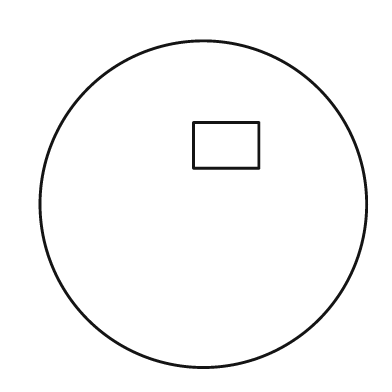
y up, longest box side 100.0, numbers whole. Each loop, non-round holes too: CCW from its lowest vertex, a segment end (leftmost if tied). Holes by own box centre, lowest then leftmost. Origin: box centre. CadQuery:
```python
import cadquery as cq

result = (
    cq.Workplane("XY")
    .moveTo(0.0, 0.0)
    .circle(50.0)
    .moveTo(-3.0, 11.0)
    .lineTo(17.0, 11.0)
    .lineTo(17.0, 25.0)
    .lineTo(-3.0, 25.0)
    .close()
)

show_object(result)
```